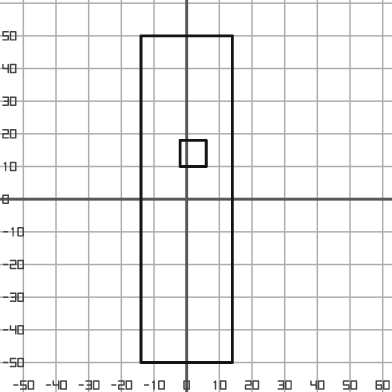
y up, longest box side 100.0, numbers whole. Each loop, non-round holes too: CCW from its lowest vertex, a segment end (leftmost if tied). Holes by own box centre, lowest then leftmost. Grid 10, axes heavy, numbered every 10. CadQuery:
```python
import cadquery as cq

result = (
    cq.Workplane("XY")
    .moveTo(-14.0, -50.0)
    .lineTo(14.0, -50.0)
    .lineTo(14.0, 50.0)
    .lineTo(-14.0, 50.0)
    .close()
    .moveTo(-2.0, 10.0)
    .lineTo(6.0, 10.0)
    .lineTo(6.0, 18.0)
    .lineTo(-2.0, 18.0)
    .close()
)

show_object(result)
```